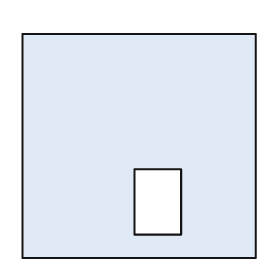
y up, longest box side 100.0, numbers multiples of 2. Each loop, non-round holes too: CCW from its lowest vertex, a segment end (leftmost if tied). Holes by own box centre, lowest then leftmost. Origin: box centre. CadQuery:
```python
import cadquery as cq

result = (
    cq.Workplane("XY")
    .moveTo(-50.0, -48.0)
    .lineTo(50.0, -48.0)
    .lineTo(50.0, 48.0)
    .lineTo(-50.0, 48.0)
    .close()
    .moveTo(-2.0, -38.0)
    .lineTo(18.0, -38.0)
    .lineTo(18.0, -10.0)
    .lineTo(-2.0, -10.0)
    .close()
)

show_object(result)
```